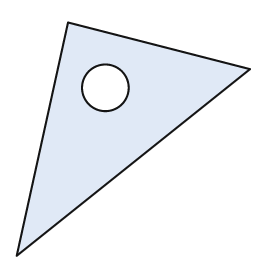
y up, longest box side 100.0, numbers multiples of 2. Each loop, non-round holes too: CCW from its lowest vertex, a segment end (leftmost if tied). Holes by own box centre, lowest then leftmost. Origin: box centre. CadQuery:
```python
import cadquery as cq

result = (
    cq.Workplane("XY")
    .moveTo(-50.0, -50.0)
    .lineTo(50.0, 30.0)
    .lineTo(-28.0, 50.0)
    .close()
    .moveTo(-12.0, 22.0)
    .circle(10.0)
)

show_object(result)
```